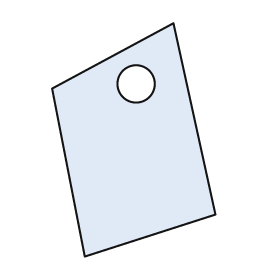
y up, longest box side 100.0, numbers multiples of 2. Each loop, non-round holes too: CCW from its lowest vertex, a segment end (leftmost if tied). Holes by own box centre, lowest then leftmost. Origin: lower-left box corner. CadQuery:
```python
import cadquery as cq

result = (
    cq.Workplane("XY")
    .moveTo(14.0, 0.0)
    .lineTo(70.0, 18.0)
    .lineTo(52.0, 100.0)
    .lineTo(0.0, 72.0)
    .close()
    .moveTo(36.0, 74.0)
    .circle(8.0)
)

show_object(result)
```